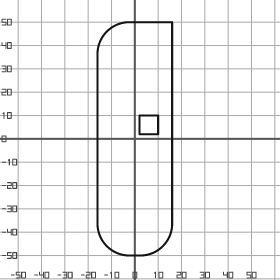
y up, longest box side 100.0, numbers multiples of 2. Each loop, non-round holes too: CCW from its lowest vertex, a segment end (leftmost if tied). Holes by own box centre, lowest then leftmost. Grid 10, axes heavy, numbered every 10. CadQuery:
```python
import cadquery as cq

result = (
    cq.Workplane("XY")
    .moveTo(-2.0, -50.0)
    .lineTo(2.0, -50.0)
    .threePointArc((12.0, -46.0), (16.0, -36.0))
    .lineTo(16.0, 50.0)
    .lineTo(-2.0, 50.0)
    .threePointArc((-12.0, 46.0), (-16.0, 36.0))
    .lineTo(-16.0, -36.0)
    .threePointArc((-12.0, -46.0), (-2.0, -50.0))
    .close()
    .moveTo(2.0, 2.0)
    .lineTo(10.0, 2.0)
    .lineTo(10.0, 10.0)
    .lineTo(2.0, 10.0)
    .close()
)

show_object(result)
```